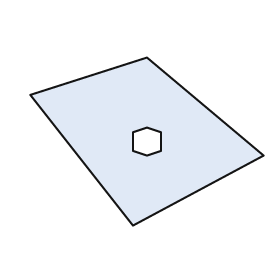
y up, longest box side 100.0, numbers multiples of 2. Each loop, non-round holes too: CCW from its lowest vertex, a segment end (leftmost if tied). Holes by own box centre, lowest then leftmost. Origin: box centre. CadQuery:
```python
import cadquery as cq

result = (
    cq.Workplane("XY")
    .moveTo(-6.0, -36.0)
    .lineTo(50.0, -6.0)
    .lineTo(0.0, 36.0)
    .lineTo(-50.0, 20.0)
    .close()
    .moveTo(0.0, -6.0)
    .lineTo(6.0, -4.0)
    .lineTo(6.0, 4.0)
    .lineTo(0.0, 6.0)
    .lineTo(-6.0, 4.0)
    .lineTo(-6.0, -4.0)
    .close()
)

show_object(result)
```